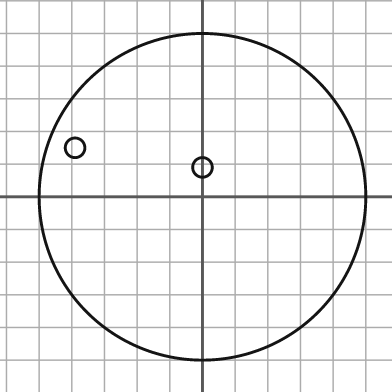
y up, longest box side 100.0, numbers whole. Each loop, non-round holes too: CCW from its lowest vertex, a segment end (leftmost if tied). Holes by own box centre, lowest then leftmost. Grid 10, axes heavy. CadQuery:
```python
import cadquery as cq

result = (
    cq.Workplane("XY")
    .moveTo(0.0, 0.0)
    .circle(50.0)
    .moveTo(0.0, 9.0)
    .circle(3.0)
    .moveTo(-39.0, 15.0)
    .circle(3.0)
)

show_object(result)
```